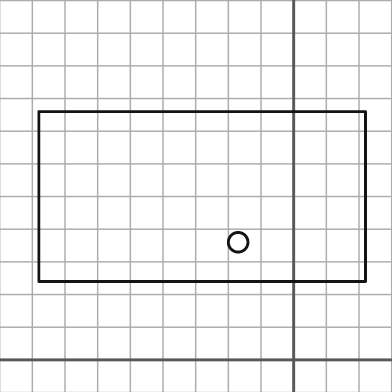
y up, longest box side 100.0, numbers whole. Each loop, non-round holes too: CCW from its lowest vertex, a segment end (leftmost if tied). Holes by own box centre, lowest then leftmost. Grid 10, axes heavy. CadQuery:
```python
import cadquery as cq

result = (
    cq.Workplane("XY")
    .moveTo(-78.0, 24.0)
    .lineTo(22.0, 24.0)
    .lineTo(22.0, 76.0)
    .lineTo(-78.0, 76.0)
    .close()
    .moveTo(-17.0, 36.0)
    .circle(3.0)
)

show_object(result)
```